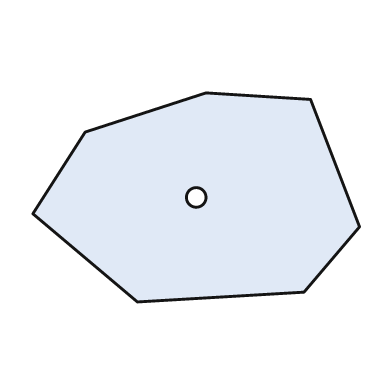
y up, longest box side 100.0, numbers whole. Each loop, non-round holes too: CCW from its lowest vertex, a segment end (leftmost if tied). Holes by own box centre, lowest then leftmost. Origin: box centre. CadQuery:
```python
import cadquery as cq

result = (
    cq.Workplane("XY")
    .moveTo(-18.0, -32.0)
    .lineTo(33.0, -29.0)
    .lineTo(50.0, -9.0)
    .lineTo(35.0, 30.0)
    .lineTo(3.0, 32.0)
    .lineTo(-34.0, 20.0)
    .lineTo(-50.0, -5.0)
    .close()
    .moveTo(0.0, 0.0)
    .circle(3.0)
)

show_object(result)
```